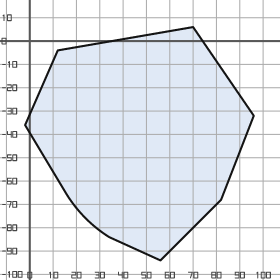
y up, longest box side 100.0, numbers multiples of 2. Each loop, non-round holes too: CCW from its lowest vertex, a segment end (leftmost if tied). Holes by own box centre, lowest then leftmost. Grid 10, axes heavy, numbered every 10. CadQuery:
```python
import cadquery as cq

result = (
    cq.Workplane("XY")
    .moveTo(56.0, -94.0)
    .lineTo(82.0, -68.0)
    .lineTo(96.0, -32.0)
    .lineTo(70.0, 6.0)
    .lineTo(12.0, -4.0)
    .lineTo(-2.0, -36.0)
    .lineTo(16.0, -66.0)
    .threePointArc((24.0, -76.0), (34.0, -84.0))
    .close()
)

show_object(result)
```